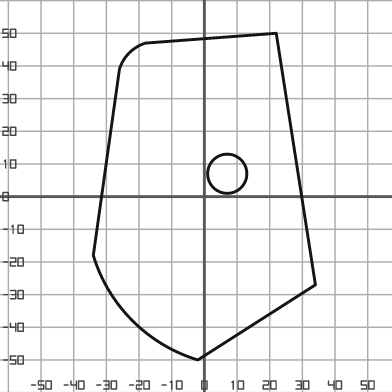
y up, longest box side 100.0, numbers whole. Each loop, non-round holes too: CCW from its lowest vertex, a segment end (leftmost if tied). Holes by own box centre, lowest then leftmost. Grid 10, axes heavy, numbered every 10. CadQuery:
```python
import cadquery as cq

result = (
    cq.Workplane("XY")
    .moveTo(-2.0, -50.0)
    .lineTo(34.0, -27.0)
    .lineTo(22.0, 50.0)
    .lineTo(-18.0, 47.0)
    .threePointArc((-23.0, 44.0), (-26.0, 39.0))
    .lineTo(-34.0, -18.0)
    .threePointArc((-22.0, -38.0), (-2.0, -50.0))
    .close()
    .moveTo(7.0, 7.0)
    .circle(6.0)
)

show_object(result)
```